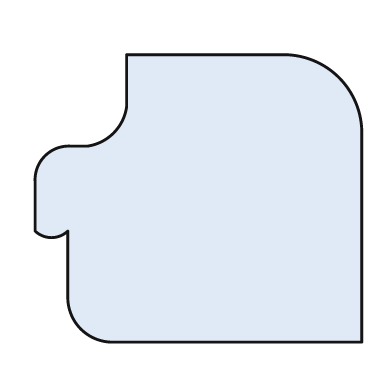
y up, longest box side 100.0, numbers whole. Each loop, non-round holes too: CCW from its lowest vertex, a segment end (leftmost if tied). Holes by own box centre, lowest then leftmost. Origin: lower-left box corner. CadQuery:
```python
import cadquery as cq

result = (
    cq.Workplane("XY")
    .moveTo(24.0, 0.0)
    .lineTo(100.0, 0.0)
    .lineTo(100.0, 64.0)
    .threePointArc((93.0, 81.0), (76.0, 88.0))
    .lineTo(28.0, 88.0)
    .lineTo(28.0, 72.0)
    .threePointArc((24.0, 64.0), (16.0, 60.0))
    .lineTo(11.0, 60.0)
    .threePointArc((3.0, 57.0), (0.0, 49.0))
    .lineTo(0.0, 34.0)
    .threePointArc((5.0, 32.0), (10.0, 34.0))
    .lineTo(10.0, 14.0)
    .threePointArc((14.0, 4.0), (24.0, 0.0))
    .close()
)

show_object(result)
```